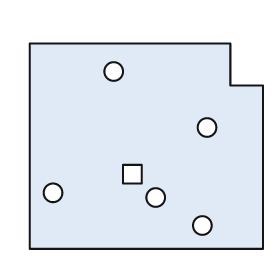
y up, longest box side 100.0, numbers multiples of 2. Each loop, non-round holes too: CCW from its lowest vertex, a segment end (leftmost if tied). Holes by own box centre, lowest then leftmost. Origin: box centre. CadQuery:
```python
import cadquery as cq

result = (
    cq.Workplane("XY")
    .moveTo(-50.0, -44.0)
    .lineTo(50.0, -44.0)
    .lineTo(50.0, 26.0)
    .lineTo(36.0, 26.0)
    .lineTo(36.0, 44.0)
    .lineTo(-50.0, 44.0)
    .close()
    .moveTo(24.0, -34.0)
    .circle(4.0)
    .moveTo(4.0, -22.0)
    .circle(4.0)
    .moveTo(-40.0, -20.0)
    .circle(4.0)
    .moveTo(-10.0, -16.0)
    .lineTo(-2.0, -16.0)
    .lineTo(-2.0, -8.0)
    .lineTo(-10.0, -8.0)
    .close()
    .moveTo(26.0, 8.0)
    .circle(4.0)
    .moveTo(-14.0, 32.0)
    .circle(4.0)
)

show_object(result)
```